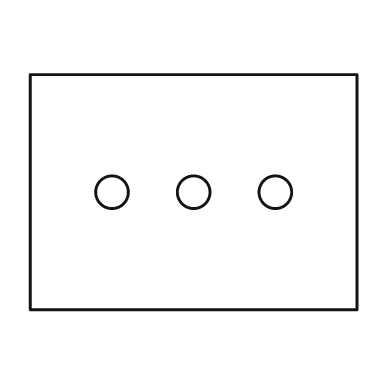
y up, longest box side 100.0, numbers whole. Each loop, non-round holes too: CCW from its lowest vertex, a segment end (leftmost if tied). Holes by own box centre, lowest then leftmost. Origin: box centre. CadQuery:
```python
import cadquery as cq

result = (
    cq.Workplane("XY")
    .moveTo(-50.0, -36.0)
    .lineTo(50.0, -36.0)
    .lineTo(50.0, 36.0)
    .lineTo(-50.0, 36.0)
    .close()
    .moveTo(-25.0, 0.0)
    .circle(5.0)
    .moveTo(0.0, 0.0)
    .circle(5.0)
    .moveTo(25.0, 0.0)
    .circle(5.0)
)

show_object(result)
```